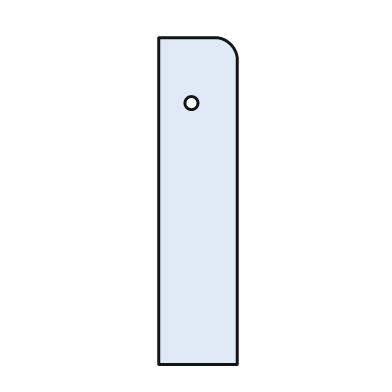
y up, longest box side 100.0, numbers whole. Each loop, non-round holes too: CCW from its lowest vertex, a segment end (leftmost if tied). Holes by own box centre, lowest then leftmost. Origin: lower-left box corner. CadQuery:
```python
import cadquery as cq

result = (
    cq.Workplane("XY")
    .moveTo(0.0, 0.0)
    .lineTo(24.0, 0.0)
    .lineTo(24.0, 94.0)
    .threePointArc((22.0, 98.0), (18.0, 100.0))
    .lineTo(0.0, 100.0)
    .close()
    .moveTo(10.0, 80.0)
    .circle(2.0)
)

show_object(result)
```